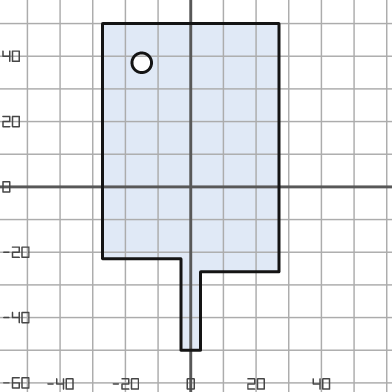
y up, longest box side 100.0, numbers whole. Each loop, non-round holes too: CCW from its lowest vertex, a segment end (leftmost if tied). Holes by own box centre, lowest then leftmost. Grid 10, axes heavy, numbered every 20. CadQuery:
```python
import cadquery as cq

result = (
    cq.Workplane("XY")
    .moveTo(-3.0, -50.0)
    .lineTo(3.0, -50.0)
    .lineTo(3.0, -26.0)
    .lineTo(27.0, -26.0)
    .lineTo(27.0, 50.0)
    .lineTo(-27.0, 50.0)
    .lineTo(-27.0, -22.0)
    .lineTo(-3.0, -22.0)
    .close()
    .moveTo(-15.0, 38.0)
    .circle(3.0)
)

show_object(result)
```